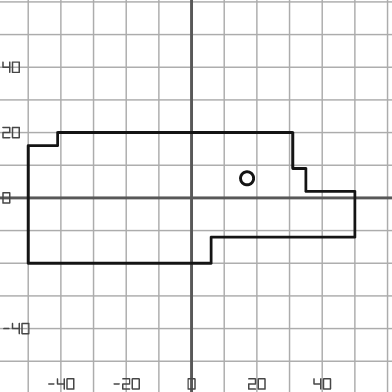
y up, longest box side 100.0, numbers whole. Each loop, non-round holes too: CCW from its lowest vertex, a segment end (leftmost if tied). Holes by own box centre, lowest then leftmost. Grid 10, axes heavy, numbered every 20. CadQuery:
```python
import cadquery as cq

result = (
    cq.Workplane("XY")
    .moveTo(-50.0, -20.0)
    .lineTo(6.0, -20.0)
    .lineTo(6.0, -12.0)
    .lineTo(50.0, -12.0)
    .lineTo(50.0, 2.0)
    .lineTo(35.0, 2.0)
    .lineTo(35.0, 9.0)
    .lineTo(31.0, 9.0)
    .lineTo(31.0, 20.0)
    .lineTo(-41.0, 20.0)
    .lineTo(-41.0, 16.0)
    .lineTo(-50.0, 16.0)
    .close()
    .moveTo(17.0, 6.0)
    .circle(2.0)
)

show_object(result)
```